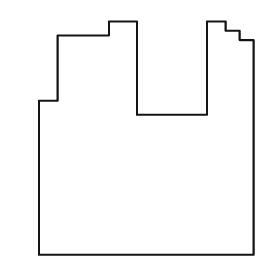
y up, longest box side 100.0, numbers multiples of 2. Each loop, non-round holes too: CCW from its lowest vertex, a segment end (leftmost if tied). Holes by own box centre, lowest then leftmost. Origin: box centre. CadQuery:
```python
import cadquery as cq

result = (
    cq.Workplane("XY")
    .moveTo(-46.0, -50.0)
    .lineTo(46.0, -50.0)
    .lineTo(46.0, 42.0)
    .lineTo(40.0, 42.0)
    .lineTo(40.0, 46.0)
    .lineTo(34.0, 46.0)
    .lineTo(34.0, 50.0)
    .lineTo(26.0, 50.0)
    .lineTo(26.0, 10.0)
    .lineTo(-4.0, 10.0)
    .lineTo(-4.0, 50.0)
    .lineTo(-16.0, 50.0)
    .lineTo(-16.0, 44.0)
    .lineTo(-38.0, 44.0)
    .lineTo(-38.0, 16.0)
    .lineTo(-46.0, 16.0)
    .close()
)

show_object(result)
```